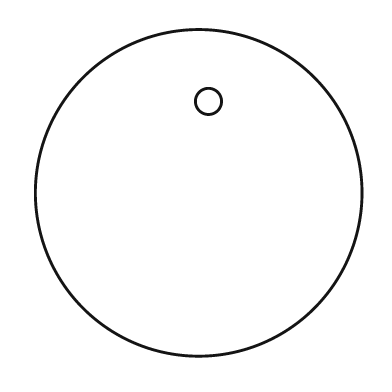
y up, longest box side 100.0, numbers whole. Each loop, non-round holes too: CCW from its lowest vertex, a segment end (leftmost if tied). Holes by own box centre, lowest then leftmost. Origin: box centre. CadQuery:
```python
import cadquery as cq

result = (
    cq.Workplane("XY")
    .moveTo(0.0, 0.0)
    .circle(50.0)
    .moveTo(3.0, 28.0)
    .circle(4.0)
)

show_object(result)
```